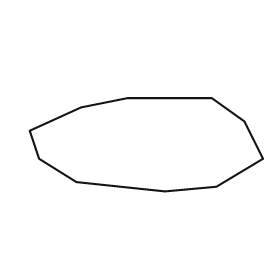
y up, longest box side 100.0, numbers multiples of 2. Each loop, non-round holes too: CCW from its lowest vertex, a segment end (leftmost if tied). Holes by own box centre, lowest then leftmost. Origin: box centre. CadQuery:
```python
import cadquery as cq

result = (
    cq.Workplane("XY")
    .moveTo(8.0, -20.0)
    .lineTo(30.0, -18.0)
    .lineTo(50.0, -6.0)
    .lineTo(42.0, 10.0)
    .lineTo(28.0, 20.0)
    .lineTo(-8.0, 20.0)
    .lineTo(-28.0, 16.0)
    .lineTo(-50.0, 6.0)
    .lineTo(-46.0, -6.0)
    .lineTo(-30.0, -16.0)
    .close()
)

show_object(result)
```